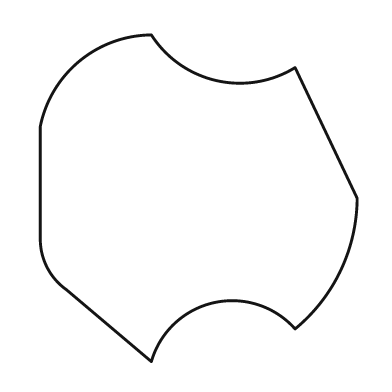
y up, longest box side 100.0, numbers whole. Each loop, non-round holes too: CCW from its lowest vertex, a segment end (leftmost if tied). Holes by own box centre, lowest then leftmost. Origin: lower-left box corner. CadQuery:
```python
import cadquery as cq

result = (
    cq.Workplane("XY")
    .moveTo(34.0, 0.0)
    .threePointArc((53.0, 18.0), (78.0, 10.0))
    .threePointArc((92.0, 28.0), (97.0, 50.0))
    .lineTo(78.0, 90.0)
    .threePointArc((54.0, 86.0), (34.0, 100.0))
    .threePointArc((12.0, 92.0), (0.0, 72.0))
    .lineTo(0.0, 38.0)
    .threePointArc((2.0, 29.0), (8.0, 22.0))
    .close()
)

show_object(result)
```